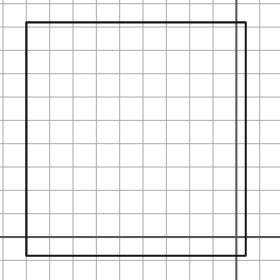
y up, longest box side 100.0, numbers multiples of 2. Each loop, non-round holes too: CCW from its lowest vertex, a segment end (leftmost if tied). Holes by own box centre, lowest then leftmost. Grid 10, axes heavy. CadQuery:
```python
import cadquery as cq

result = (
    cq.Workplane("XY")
    .moveTo(-90.0, -8.0)
    .lineTo(4.0, -8.0)
    .lineTo(4.0, 92.0)
    .lineTo(-90.0, 92.0)
    .close()
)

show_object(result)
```